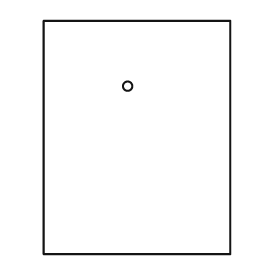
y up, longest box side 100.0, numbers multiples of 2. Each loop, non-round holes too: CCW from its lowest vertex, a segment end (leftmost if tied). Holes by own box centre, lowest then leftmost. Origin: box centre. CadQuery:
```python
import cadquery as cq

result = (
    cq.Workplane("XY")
    .moveTo(-40.0, -50.0)
    .lineTo(40.0, -50.0)
    .lineTo(40.0, 50.0)
    .lineTo(-40.0, 50.0)
    .close()
    .moveTo(-4.0, 22.0)
    .circle(2.0)
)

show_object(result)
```